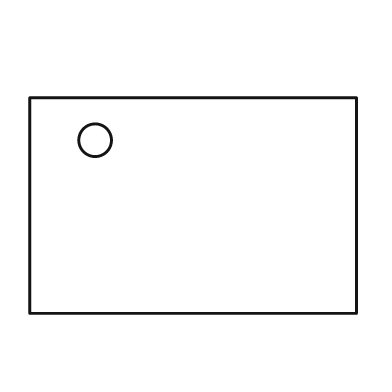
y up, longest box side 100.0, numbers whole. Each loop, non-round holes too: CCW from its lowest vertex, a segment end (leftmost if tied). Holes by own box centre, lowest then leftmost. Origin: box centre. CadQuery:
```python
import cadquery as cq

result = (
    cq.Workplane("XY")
    .moveTo(-50.0, -33.0)
    .lineTo(50.0, -33.0)
    .lineTo(50.0, 33.0)
    .lineTo(-50.0, 33.0)
    .close()
    .moveTo(-30.0, 20.0)
    .circle(5.0)
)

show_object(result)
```